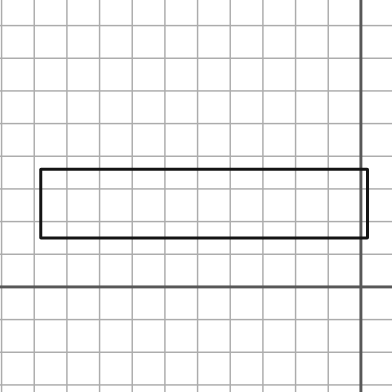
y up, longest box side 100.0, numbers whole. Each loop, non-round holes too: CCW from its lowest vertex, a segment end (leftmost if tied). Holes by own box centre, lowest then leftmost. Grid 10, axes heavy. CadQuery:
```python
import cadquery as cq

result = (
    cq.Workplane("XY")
    .moveTo(-98.0, 15.0)
    .lineTo(2.0, 15.0)
    .lineTo(2.0, 36.0)
    .lineTo(-98.0, 36.0)
    .close()
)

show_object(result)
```